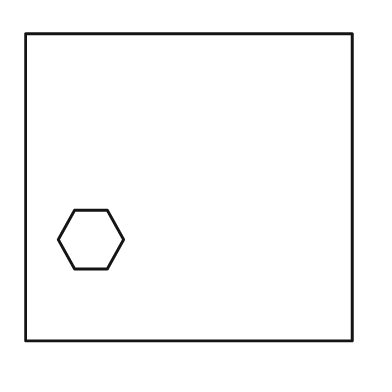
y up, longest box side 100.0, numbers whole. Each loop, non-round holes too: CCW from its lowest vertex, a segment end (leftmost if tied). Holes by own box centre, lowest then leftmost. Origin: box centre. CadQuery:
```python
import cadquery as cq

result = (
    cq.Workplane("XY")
    .moveTo(-50.0, -47.0)
    .lineTo(50.0, -47.0)
    .lineTo(50.0, 47.0)
    .lineTo(-50.0, 47.0)
    .close()
    .moveTo(-35.0, -25.0)
    .lineTo(-25.0, -25.0)
    .lineTo(-20.0, -16.0)
    .lineTo(-25.0, -7.0)
    .lineTo(-35.0, -7.0)
    .lineTo(-40.0, -16.0)
    .close()
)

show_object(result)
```